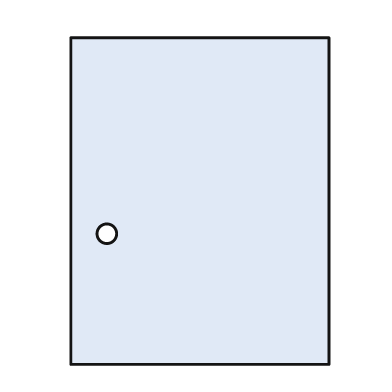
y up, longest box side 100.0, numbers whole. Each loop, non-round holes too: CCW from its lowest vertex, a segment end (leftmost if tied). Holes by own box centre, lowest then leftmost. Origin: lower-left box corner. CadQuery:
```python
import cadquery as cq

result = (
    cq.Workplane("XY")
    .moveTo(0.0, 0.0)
    .lineTo(79.0, 0.0)
    .lineTo(79.0, 100.0)
    .lineTo(0.0, 100.0)
    .close()
    .moveTo(11.0, 40.0)
    .circle(3.0)
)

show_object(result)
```